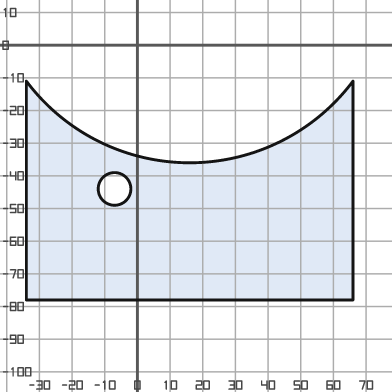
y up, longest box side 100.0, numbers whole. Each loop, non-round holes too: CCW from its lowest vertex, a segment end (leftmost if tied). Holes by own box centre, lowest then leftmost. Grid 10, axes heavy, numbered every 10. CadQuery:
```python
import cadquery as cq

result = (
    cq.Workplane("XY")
    .moveTo(-34.0, -78.0)
    .lineTo(66.0, -78.0)
    .lineTo(66.0, -11.0)
    .threePointArc((16.0, -36.0), (-34.0, -11.0))
    .close()
    .moveTo(-7.0, -44.0)
    .circle(5.0)
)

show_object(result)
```